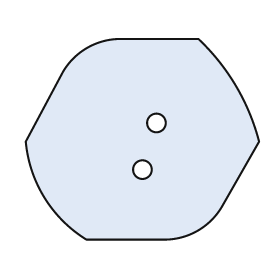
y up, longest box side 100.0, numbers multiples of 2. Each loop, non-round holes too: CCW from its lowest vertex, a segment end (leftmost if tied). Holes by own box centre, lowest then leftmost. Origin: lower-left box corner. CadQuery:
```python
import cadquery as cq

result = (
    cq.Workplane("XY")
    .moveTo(26.0, 0.0)
    .lineTo(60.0, 0.0)
    .threePointArc((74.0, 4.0), (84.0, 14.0))
    .lineTo(100.0, 42.0)
    .threePointArc((90.0, 66.0), (74.0, 86.0))
    .lineTo(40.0, 86.0)
    .threePointArc((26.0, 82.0), (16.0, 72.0))
    .lineTo(0.0, 42.0)
    .threePointArc((8.0, 18.0), (26.0, 0.0))
    .close()
    .moveTo(50.0, 30.0)
    .circle(4.0)
    .moveTo(56.0, 50.0)
    .circle(4.0)
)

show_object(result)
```